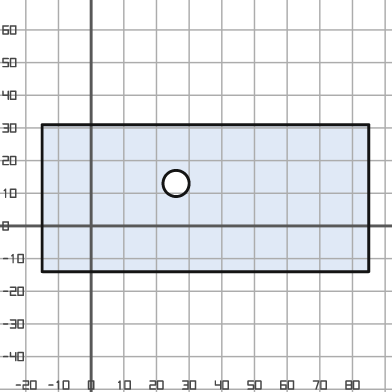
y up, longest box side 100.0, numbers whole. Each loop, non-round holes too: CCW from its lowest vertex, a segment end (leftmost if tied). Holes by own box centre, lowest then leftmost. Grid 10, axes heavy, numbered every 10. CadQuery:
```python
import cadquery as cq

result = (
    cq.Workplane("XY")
    .moveTo(-15.0, -14.0)
    .lineTo(85.0, -14.0)
    .lineTo(85.0, 31.0)
    .lineTo(-15.0, 31.0)
    .close()
    .moveTo(26.0, 13.0)
    .circle(4.0)
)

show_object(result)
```